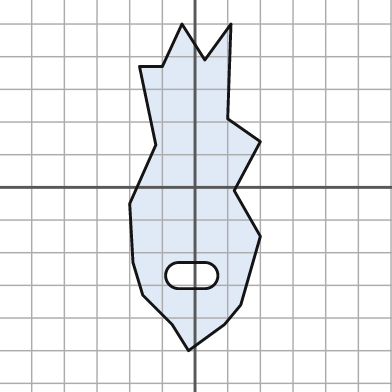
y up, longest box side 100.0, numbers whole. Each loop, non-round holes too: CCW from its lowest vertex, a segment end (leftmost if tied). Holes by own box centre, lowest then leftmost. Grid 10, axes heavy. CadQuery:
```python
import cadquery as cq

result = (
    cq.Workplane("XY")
    .moveTo(-2.0, -50.0)
    .lineTo(9.0, -42.0)
    .lineTo(14.0, -36.0)
    .lineTo(20.0, -15.0)
    .lineTo(12.0, -1.0)
    .lineTo(20.0, 14.0)
    .lineTo(10.0, 21.0)
    .lineTo(11.0, 50.0)
    .lineTo(3.0, 39.0)
    .lineTo(-4.0, 50.0)
    .lineTo(-10.0, 37.0)
    .lineTo(-17.0, 37.0)
    .lineTo(-12.0, 13.0)
    .lineTo(-20.0, -5.0)
    .lineTo(-19.0, -23.0)
    .lineTo(-16.0, -33.0)
    .lineTo(-7.0, -42.0)
    .close()
    .moveTo(-5.0, -31.0)
    .lineTo(3.0, -31.0)
    .threePointArc((7.0, -27.0), (3.0, -23.0))
    .lineTo(-5.0, -23.0)
    .threePointArc((-9.0, -27.0), (-5.0, -31.0))
    .close()
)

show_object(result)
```